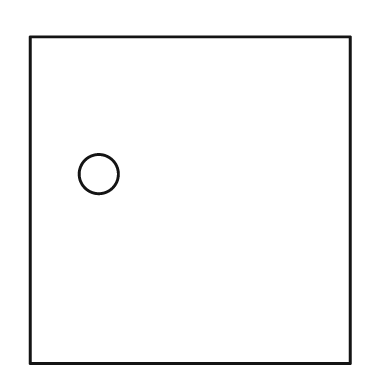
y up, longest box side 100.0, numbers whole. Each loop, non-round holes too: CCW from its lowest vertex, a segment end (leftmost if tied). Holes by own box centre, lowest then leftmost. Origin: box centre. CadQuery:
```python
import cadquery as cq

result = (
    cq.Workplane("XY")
    .moveTo(-49.0, -50.0)
    .lineTo(49.0, -50.0)
    .lineTo(49.0, 50.0)
    .lineTo(-49.0, 50.0)
    .close()
    .moveTo(-28.0, 8.0)
    .circle(6.0)
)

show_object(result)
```